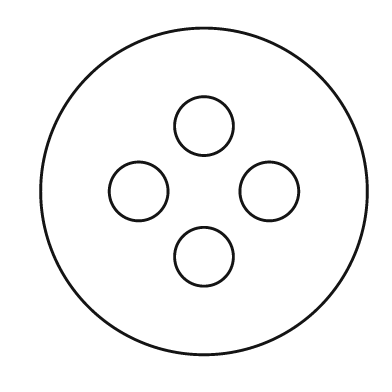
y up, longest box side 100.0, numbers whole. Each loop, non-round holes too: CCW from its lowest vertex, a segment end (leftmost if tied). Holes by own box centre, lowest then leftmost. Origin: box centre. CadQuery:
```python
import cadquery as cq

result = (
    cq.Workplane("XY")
    .moveTo(0.0, 0.0)
    .circle(50.0)
    .moveTo(0.0, -20.0)
    .circle(9.0)
    .moveTo(-20.0, 0.0)
    .circle(9.0)
    .moveTo(20.0, 0.0)
    .circle(9.0)
    .moveTo(0.0, 20.0)
    .circle(9.0)
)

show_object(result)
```